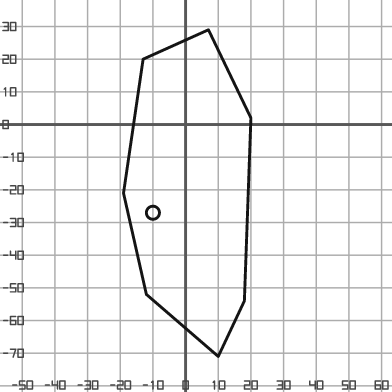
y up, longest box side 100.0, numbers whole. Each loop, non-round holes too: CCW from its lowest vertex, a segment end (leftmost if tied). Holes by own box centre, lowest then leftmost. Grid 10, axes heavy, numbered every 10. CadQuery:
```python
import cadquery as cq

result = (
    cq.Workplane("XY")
    .moveTo(10.0, -71.0)
    .lineTo(18.0, -54.0)
    .lineTo(20.0, 2.0)
    .lineTo(7.0, 29.0)
    .lineTo(-13.0, 20.0)
    .lineTo(-19.0, -21.0)
    .lineTo(-12.0, -52.0)
    .close()
    .moveTo(-10.0, -27.0)
    .circle(2.0)
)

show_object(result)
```